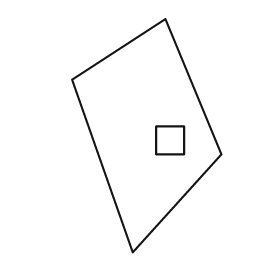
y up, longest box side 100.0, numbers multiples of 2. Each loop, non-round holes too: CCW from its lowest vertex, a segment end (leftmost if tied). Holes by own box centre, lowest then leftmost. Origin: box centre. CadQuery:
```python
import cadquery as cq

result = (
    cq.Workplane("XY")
    .moveTo(-6.0, -50.0)
    .lineTo(32.0, -8.0)
    .lineTo(8.0, 50.0)
    .lineTo(-32.0, 24.0)
    .close()
    .moveTo(4.0, -8.0)
    .lineTo(16.0, -8.0)
    .lineTo(16.0, 4.0)
    .lineTo(4.0, 4.0)
    .close()
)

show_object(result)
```